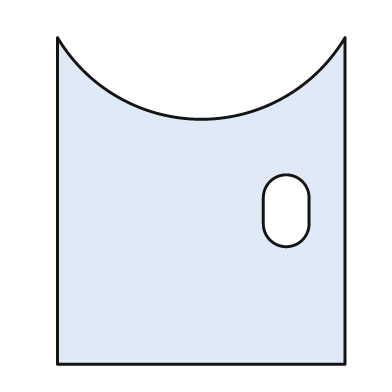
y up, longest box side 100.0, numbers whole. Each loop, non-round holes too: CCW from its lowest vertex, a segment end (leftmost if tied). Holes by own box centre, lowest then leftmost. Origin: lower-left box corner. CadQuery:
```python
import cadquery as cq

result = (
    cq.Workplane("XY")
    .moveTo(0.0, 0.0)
    .lineTo(88.0, 0.0)
    .lineTo(88.0, 100.0)
    .threePointArc((44.0, 75.0), (0.0, 100.0))
    .close()
    .moveTo(63.0, 43.0)
    .threePointArc((70.0, 36.0), (77.0, 43.0))
    .lineTo(77.0, 51.0)
    .threePointArc((70.0, 58.0), (63.0, 51.0))
    .close()
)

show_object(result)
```